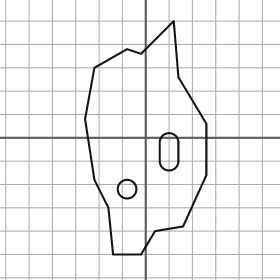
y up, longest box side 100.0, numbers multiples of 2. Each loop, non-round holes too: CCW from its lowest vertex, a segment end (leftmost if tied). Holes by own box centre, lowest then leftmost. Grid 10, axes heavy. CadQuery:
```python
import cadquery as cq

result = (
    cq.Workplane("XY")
    .moveTo(-14.0, -50.0)
    .lineTo(-2.0, -50.0)
    .lineTo(4.0, -40.0)
    .lineTo(16.0, -38.0)
    .lineTo(26.0, -16.0)
    .lineTo(26.0, 6.0)
    .lineTo(14.0, 26.0)
    .lineTo(12.0, 50.0)
    .lineTo(-2.0, 36.0)
    .lineTo(-8.0, 38.0)
    .lineTo(-22.0, 30.0)
    .lineTo(-26.0, 8.0)
    .lineTo(-22.0, -18.0)
    .lineTo(-16.0, -30.0)
    .close()
    .moveTo(-8.0, -22.0)
    .circle(4.0)
    .moveTo(6.0, -10.0)
    .threePointArc((10.0, -14.0), (14.0, -10.0))
    .lineTo(14.0, -2.0)
    .threePointArc((10.0, 2.0), (6.0, -2.0))
    .close()
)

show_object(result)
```